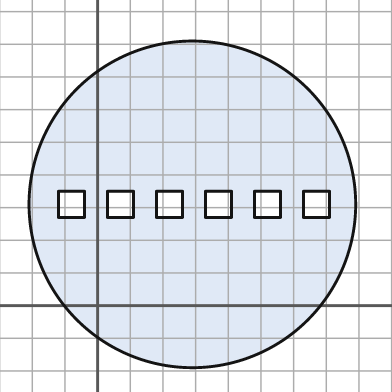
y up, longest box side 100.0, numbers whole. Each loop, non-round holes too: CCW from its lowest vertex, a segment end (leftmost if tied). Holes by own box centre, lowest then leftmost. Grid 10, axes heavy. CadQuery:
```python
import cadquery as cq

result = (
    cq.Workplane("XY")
    .moveTo(29.0, 31.0)
    .circle(50.0)
    .moveTo(-12.0, 27.0)
    .lineTo(-4.0, 27.0)
    .lineTo(-4.0, 35.0)
    .lineTo(-12.0, 35.0)
    .close()
    .moveTo(3.0, 27.0)
    .lineTo(11.0, 27.0)
    .lineTo(11.0, 35.0)
    .lineTo(3.0, 35.0)
    .close()
    .moveTo(18.0, 27.0)
    .lineTo(26.0, 27.0)
    .lineTo(26.0, 35.0)
    .lineTo(18.0, 35.0)
    .close()
    .moveTo(33.0, 27.0)
    .lineTo(41.0, 27.0)
    .lineTo(41.0, 35.0)
    .lineTo(33.0, 35.0)
    .close()
    .moveTo(48.0, 27.0)
    .lineTo(56.0, 27.0)
    .lineTo(56.0, 35.0)
    .lineTo(48.0, 35.0)
    .close()
    .moveTo(63.0, 27.0)
    .lineTo(71.0, 27.0)
    .lineTo(71.0, 35.0)
    .lineTo(63.0, 35.0)
    .close()
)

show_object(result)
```